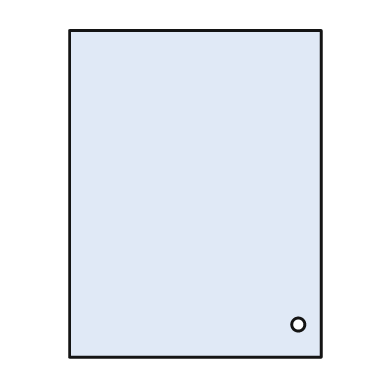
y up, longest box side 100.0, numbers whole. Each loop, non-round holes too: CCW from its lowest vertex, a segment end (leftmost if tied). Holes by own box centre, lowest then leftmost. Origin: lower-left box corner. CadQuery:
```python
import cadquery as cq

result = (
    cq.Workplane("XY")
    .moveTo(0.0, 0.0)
    .lineTo(77.0, 0.0)
    .lineTo(77.0, 100.0)
    .lineTo(0.0, 100.0)
    .close()
    .moveTo(70.0, 10.0)
    .circle(2.0)
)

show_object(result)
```